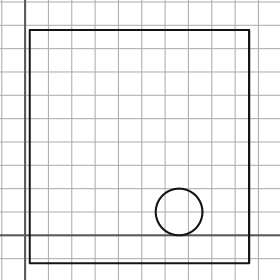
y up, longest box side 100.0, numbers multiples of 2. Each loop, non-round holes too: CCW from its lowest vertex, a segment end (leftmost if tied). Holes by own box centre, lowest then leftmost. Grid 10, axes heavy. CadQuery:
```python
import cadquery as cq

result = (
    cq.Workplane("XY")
    .moveTo(2.0, -12.0)
    .lineTo(96.0, -12.0)
    .lineTo(96.0, 88.0)
    .lineTo(2.0, 88.0)
    .close()
    .moveTo(66.0, 10.0)
    .circle(10.0)
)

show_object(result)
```